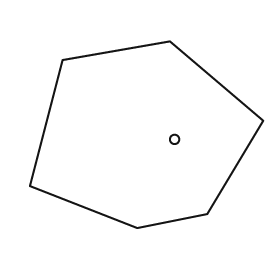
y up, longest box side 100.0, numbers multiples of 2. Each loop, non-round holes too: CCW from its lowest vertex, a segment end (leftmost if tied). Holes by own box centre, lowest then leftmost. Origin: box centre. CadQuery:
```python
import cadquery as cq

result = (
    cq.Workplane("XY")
    .moveTo(-4.0, -40.0)
    .lineTo(26.0, -34.0)
    .lineTo(50.0, 6.0)
    .lineTo(10.0, 40.0)
    .lineTo(-36.0, 32.0)
    .lineTo(-50.0, -22.0)
    .close()
    .moveTo(12.0, -2.0)
    .circle(2.0)
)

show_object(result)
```